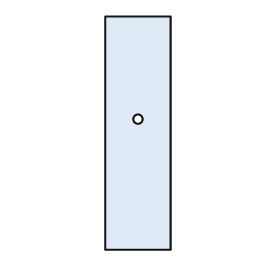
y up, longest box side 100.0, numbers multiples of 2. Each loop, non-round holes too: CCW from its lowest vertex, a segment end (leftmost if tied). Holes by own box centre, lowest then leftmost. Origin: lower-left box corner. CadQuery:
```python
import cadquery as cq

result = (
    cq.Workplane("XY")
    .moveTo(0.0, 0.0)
    .lineTo(28.0, 0.0)
    .lineTo(28.0, 100.0)
    .lineTo(0.0, 100.0)
    .close()
    .moveTo(14.0, 56.0)
    .circle(2.0)
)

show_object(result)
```